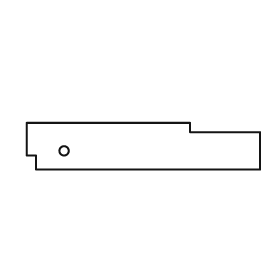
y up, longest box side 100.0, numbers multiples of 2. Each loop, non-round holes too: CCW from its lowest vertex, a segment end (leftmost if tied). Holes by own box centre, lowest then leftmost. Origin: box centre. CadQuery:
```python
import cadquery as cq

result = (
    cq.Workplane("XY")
    .moveTo(-46.0, -10.0)
    .lineTo(50.0, -10.0)
    .lineTo(50.0, 6.0)
    .lineTo(20.0, 6.0)
    .lineTo(20.0, 10.0)
    .lineTo(-50.0, 10.0)
    .lineTo(-50.0, -4.0)
    .lineTo(-46.0, -4.0)
    .close()
    .moveTo(-34.0, -2.0)
    .circle(2.0)
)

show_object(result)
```